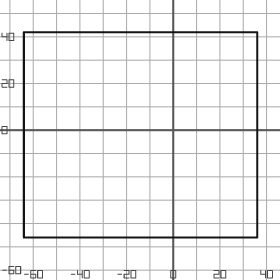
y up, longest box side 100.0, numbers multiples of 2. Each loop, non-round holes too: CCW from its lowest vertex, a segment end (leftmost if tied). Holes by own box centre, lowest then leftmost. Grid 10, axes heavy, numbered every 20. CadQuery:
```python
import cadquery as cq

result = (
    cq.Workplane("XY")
    .moveTo(-64.0, -46.0)
    .lineTo(36.0, -46.0)
    .lineTo(36.0, 42.0)
    .lineTo(-64.0, 42.0)
    .close()
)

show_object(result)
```